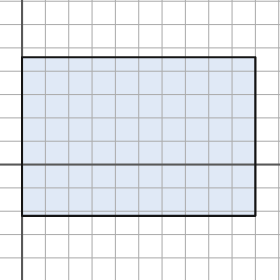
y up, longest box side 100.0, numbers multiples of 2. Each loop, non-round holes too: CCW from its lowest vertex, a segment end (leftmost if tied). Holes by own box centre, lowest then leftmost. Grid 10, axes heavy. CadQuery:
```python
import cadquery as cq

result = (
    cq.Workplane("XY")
    .moveTo(0.0, -22.0)
    .lineTo(100.0, -22.0)
    .lineTo(100.0, 46.0)
    .lineTo(0.0, 46.0)
    .close()
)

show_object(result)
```